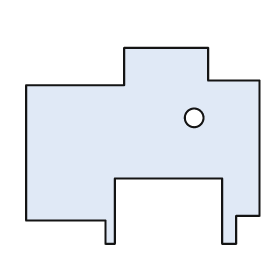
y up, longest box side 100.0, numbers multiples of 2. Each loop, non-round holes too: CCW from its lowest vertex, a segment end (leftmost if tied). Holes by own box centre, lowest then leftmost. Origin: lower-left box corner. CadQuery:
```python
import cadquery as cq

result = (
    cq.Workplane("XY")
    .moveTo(34.0, 0.0)
    .lineTo(38.0, 0.0)
    .lineTo(38.0, 28.0)
    .lineTo(84.0, 28.0)
    .lineTo(84.0, 0.0)
    .lineTo(90.0, 0.0)
    .lineTo(90.0, 12.0)
    .lineTo(100.0, 12.0)
    .lineTo(100.0, 70.0)
    .lineTo(78.0, 70.0)
    .lineTo(78.0, 84.0)
    .lineTo(42.0, 84.0)
    .lineTo(42.0, 68.0)
    .lineTo(0.0, 68.0)
    .lineTo(0.0, 10.0)
    .lineTo(34.0, 10.0)
    .close()
    .moveTo(72.0, 54.0)
    .circle(4.0)
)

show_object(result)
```